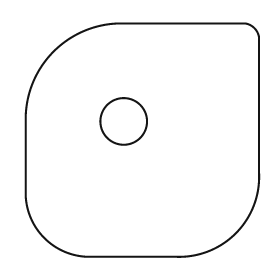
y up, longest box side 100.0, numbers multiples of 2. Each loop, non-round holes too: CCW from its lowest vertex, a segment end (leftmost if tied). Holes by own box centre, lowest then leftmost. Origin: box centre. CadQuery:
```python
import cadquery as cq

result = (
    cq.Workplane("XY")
    .moveTo(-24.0, -50.0)
    .lineTo(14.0, -50.0)
    .threePointArc((40.0, -40.0), (50.0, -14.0))
    .lineTo(50.0, 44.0)
    .threePointArc((48.0, 48.0), (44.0, 50.0))
    .lineTo(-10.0, 50.0)
    .threePointArc((-38.0, 38.0), (-50.0, 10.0))
    .lineTo(-50.0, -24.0)
    .threePointArc((-42.0, -42.0), (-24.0, -50.0))
    .close()
    .moveTo(-8.0, 8.0)
    .circle(10.0)
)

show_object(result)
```